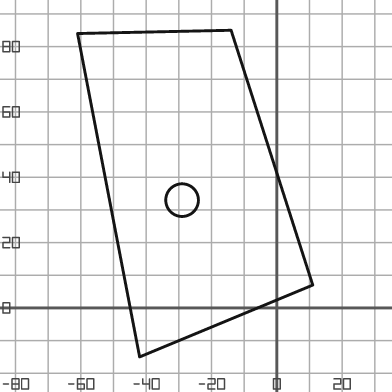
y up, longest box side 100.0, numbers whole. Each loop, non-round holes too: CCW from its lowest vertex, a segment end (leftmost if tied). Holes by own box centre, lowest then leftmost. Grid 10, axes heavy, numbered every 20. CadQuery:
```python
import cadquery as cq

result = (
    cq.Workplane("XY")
    .moveTo(-42.0, -15.0)
    .lineTo(11.0, 7.0)
    .lineTo(-14.0, 85.0)
    .lineTo(-61.0, 84.0)
    .close()
    .moveTo(-29.0, 33.0)
    .circle(5.0)
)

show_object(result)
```